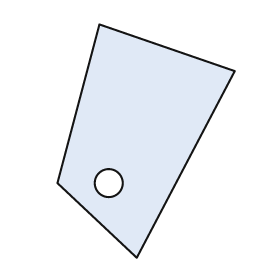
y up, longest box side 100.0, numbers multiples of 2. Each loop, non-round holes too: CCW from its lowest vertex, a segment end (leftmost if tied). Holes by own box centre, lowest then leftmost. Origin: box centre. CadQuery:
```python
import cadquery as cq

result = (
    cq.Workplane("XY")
    .moveTo(-4.0, -50.0)
    .lineTo(38.0, 30.0)
    .lineTo(-20.0, 50.0)
    .lineTo(-38.0, -18.0)
    .close()
    .moveTo(-16.0, -18.0)
    .circle(6.0)
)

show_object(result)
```